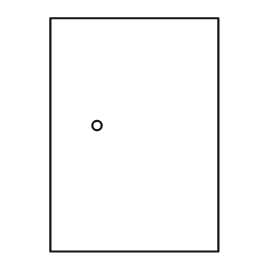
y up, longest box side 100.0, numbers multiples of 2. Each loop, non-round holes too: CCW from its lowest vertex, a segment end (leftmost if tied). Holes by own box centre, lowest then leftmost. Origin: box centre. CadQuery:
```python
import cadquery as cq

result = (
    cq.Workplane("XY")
    .moveTo(-36.0, -50.0)
    .lineTo(36.0, -50.0)
    .lineTo(36.0, 50.0)
    .lineTo(-36.0, 50.0)
    .close()
    .moveTo(-16.0, 4.0)
    .circle(2.0)
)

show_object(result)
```